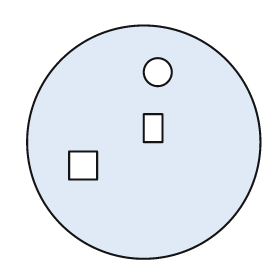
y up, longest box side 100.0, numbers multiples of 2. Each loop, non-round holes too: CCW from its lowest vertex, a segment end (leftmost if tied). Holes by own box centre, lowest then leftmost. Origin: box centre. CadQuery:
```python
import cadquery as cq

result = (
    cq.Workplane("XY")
    .moveTo(0.0, 0.0)
    .circle(50.0)
    .moveTo(-32.0, -16.0)
    .lineTo(-20.0, -16.0)
    .lineTo(-20.0, -4.0)
    .lineTo(-32.0, -4.0)
    .close()
    .moveTo(0.0, 0.0)
    .lineTo(8.0, 0.0)
    .lineTo(8.0, 12.0)
    .lineTo(0.0, 12.0)
    .close()
    .moveTo(6.0, 30.0)
    .circle(6.0)
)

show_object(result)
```